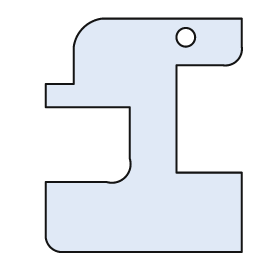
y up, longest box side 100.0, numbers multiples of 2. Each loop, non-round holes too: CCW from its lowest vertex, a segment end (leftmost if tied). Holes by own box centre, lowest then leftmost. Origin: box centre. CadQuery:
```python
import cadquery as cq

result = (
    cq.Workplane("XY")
    .moveTo(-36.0, -50.0)
    .lineTo(42.0, -50.0)
    .lineTo(42.0, -16.0)
    .lineTo(14.0, -16.0)
    .lineTo(14.0, 30.0)
    .lineTo(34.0, 30.0)
    .threePointArc((40.0, 32.0), (42.0, 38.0))
    .lineTo(42.0, 50.0)
    .lineTo(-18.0, 50.0)
    .threePointArc((-26.0, 46.0), (-30.0, 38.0))
    .lineTo(-30.0, 22.0)
    .lineTo(-42.0, 22.0)
    .lineTo(-42.0, 12.0)
    .lineTo(-6.0, 12.0)
    .lineTo(-6.0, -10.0)
    .threePointArc((-8.0, -18.0), (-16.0, -20.0))
    .lineTo(-42.0, -20.0)
    .lineTo(-42.0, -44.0)
    .threePointArc((-40.0, -48.0), (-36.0, -50.0))
    .close()
    .moveTo(18.0, 42.0)
    .circle(4.0)
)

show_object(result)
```